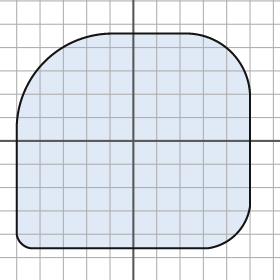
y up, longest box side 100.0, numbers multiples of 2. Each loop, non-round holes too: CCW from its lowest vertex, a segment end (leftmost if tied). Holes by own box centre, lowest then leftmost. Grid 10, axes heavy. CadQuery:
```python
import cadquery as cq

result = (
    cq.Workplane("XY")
    .moveTo(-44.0, -46.0)
    .lineTo(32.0, -46.0)
    .threePointArc((44.0, -40.0), (50.0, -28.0))
    .lineTo(50.0, 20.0)
    .threePointArc((42.0, 38.0), (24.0, 46.0))
    .lineTo(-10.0, 46.0)
    .threePointArc((-38.0, 34.0), (-50.0, 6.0))
    .lineTo(-50.0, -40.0)
    .threePointArc((-48.0, -44.0), (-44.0, -46.0))
    .close()
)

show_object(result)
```